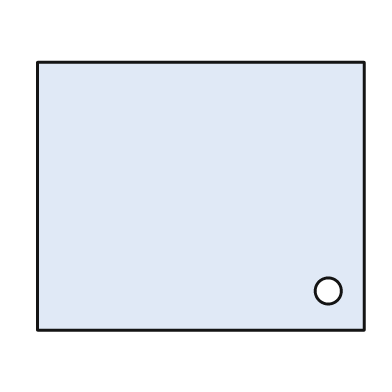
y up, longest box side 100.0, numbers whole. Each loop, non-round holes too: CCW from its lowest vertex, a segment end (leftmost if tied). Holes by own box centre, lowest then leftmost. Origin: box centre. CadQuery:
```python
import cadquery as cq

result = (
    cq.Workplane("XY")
    .moveTo(-50.0, -41.0)
    .lineTo(50.0, -41.0)
    .lineTo(50.0, 41.0)
    .lineTo(-50.0, 41.0)
    .close()
    .moveTo(39.0, -29.0)
    .circle(4.0)
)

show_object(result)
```